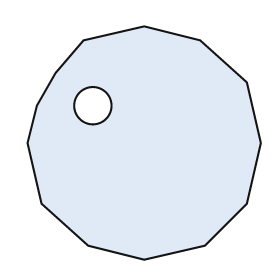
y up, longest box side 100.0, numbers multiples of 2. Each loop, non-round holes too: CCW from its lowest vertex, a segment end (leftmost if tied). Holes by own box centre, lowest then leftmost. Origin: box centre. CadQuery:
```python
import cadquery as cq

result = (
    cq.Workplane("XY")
    .moveTo(0.0, -50.0)
    .lineTo(26.0, -44.0)
    .lineTo(44.0, -26.0)
    .lineTo(50.0, 0.0)
    .lineTo(44.0, 26.0)
    .lineTo(24.0, 44.0)
    .lineTo(0.0, 50.0)
    .lineTo(-26.0, 44.0)
    .lineTo(-38.0, 30.0)
    .lineTo(-46.0, 16.0)
    .lineTo(-50.0, 0.0)
    .lineTo(-44.0, -26.0)
    .lineTo(-24.0, -44.0)
    .close()
    .moveTo(-22.0, 16.0)
    .circle(8.0)
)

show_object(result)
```